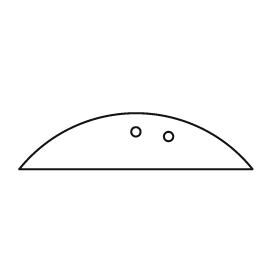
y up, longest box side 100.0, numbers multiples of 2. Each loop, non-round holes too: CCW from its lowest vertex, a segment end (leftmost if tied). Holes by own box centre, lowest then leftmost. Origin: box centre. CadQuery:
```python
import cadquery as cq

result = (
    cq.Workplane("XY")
    .moveTo(-50.0, -12.0)
    .lineTo(50.0, -12.0)
    .threePointArc((0.0, 12.0), (-50.0, -12.0))
    .close()
    .moveTo(14.0, 2.0)
    .circle(2.0)
    .moveTo(0.0, 4.0)
    .circle(2.0)
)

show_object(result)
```